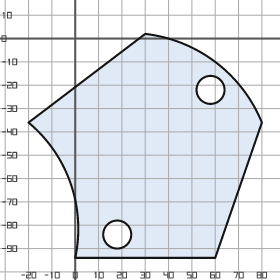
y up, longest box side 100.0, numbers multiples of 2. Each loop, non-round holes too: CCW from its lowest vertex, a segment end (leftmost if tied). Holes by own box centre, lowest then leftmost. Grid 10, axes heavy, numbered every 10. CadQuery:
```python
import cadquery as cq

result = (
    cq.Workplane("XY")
    .moveTo(0.0, -94.0)
    .lineTo(60.0, -94.0)
    .lineTo(80.0, -36.0)
    .threePointArc((60.0, -10.0), (30.0, 2.0))
    .lineTo(-20.0, -36.0)
    .threePointArc((-2.0, -62.0), (0.0, -94.0))
    .close()
    .moveTo(18.0, -84.0)
    .circle(6.0)
    .moveTo(58.0, -22.0)
    .circle(6.0)
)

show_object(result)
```